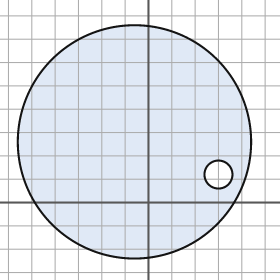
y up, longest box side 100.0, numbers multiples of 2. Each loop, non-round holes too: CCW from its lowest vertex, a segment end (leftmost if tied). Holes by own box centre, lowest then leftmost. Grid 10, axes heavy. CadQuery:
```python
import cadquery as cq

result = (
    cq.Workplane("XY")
    .moveTo(-6.0, 26.0)
    .circle(50.0)
    .moveTo(30.0, 12.0)
    .circle(6.0)
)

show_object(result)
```